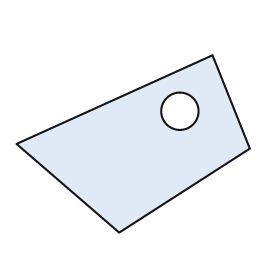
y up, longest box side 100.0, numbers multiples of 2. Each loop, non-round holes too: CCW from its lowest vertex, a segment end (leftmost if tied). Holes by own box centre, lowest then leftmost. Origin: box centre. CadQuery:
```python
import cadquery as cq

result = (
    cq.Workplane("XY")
    .moveTo(-6.0, -38.0)
    .lineTo(50.0, -2.0)
    .lineTo(34.0, 38.0)
    .lineTo(-50.0, 0.0)
    .close()
    .moveTo(20.0, 14.0)
    .circle(8.0)
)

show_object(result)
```